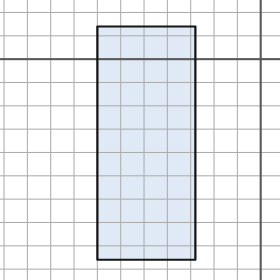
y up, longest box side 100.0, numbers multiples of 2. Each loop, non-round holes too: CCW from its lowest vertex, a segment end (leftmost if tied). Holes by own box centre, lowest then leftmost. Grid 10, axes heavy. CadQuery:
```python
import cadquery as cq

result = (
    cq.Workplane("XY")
    .moveTo(-70.0, -86.0)
    .lineTo(-28.0, -86.0)
    .lineTo(-28.0, 14.0)
    .lineTo(-70.0, 14.0)
    .close()
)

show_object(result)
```